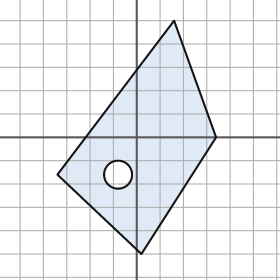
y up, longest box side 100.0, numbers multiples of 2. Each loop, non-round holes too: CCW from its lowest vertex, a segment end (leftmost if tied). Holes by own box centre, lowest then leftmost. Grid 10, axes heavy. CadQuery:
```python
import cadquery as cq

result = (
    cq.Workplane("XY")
    .moveTo(2.0, -50.0)
    .lineTo(34.0, 0.0)
    .lineTo(16.0, 50.0)
    .lineTo(-34.0, -16.0)
    .close()
    .moveTo(-8.0, -16.0)
    .circle(6.0)
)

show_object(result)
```